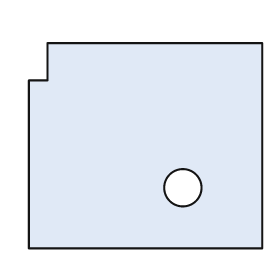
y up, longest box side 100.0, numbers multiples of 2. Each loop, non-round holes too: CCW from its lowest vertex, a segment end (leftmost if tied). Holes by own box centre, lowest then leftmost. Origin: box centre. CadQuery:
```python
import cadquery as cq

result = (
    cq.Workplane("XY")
    .moveTo(-50.0, -44.0)
    .lineTo(50.0, -44.0)
    .lineTo(50.0, 44.0)
    .lineTo(-42.0, 44.0)
    .lineTo(-42.0, 28.0)
    .lineTo(-50.0, 28.0)
    .close()
    .moveTo(16.0, -18.0)
    .circle(8.0)
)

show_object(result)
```